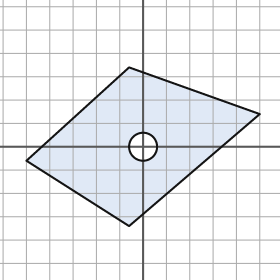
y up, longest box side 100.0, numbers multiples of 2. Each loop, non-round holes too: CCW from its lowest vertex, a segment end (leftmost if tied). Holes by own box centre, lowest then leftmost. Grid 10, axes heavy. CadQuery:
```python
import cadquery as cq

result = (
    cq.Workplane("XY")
    .moveTo(-6.0, -34.0)
    .lineTo(50.0, 14.0)
    .lineTo(-6.0, 34.0)
    .lineTo(-50.0, -6.0)
    .close()
    .moveTo(0.0, 0.0)
    .circle(6.0)
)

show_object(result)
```